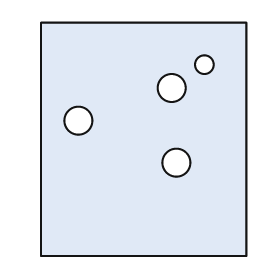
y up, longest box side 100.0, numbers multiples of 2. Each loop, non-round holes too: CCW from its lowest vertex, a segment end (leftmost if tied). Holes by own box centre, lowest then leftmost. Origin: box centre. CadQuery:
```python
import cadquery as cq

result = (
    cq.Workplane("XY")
    .moveTo(-44.0, -50.0)
    .lineTo(44.0, -50.0)
    .lineTo(44.0, 50.0)
    .lineTo(-44.0, 50.0)
    .close()
    .moveTo(14.0, -10.0)
    .circle(6.0)
    .moveTo(-28.0, 8.0)
    .circle(6.0)
    .moveTo(12.0, 22.0)
    .circle(6.0)
    .moveTo(26.0, 32.0)
    .circle(4.0)
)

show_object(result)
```